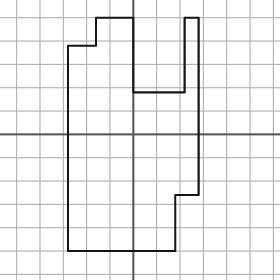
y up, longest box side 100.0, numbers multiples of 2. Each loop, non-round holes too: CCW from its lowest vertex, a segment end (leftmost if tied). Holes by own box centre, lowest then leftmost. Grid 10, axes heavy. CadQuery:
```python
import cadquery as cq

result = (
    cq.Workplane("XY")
    .moveTo(-28.0, -50.0)
    .lineTo(18.0, -50.0)
    .lineTo(18.0, -26.0)
    .lineTo(28.0, -26.0)
    .lineTo(28.0, 50.0)
    .lineTo(22.0, 50.0)
    .lineTo(22.0, 18.0)
    .lineTo(0.0, 18.0)
    .lineTo(0.0, 50.0)
    .lineTo(-16.0, 50.0)
    .lineTo(-16.0, 38.0)
    .lineTo(-28.0, 38.0)
    .close()
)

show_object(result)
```